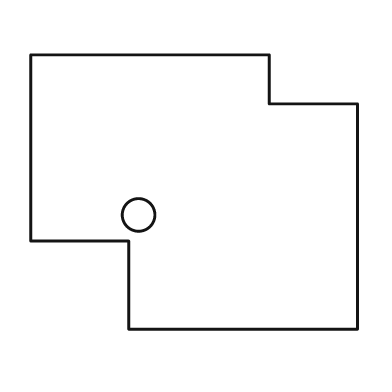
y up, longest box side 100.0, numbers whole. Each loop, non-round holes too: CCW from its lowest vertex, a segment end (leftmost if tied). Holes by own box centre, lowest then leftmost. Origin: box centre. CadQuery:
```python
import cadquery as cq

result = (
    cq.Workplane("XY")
    .moveTo(-20.0, -42.0)
    .lineTo(50.0, -42.0)
    .lineTo(50.0, 27.0)
    .lineTo(23.0, 27.0)
    .lineTo(23.0, 42.0)
    .lineTo(-50.0, 42.0)
    .lineTo(-50.0, -15.0)
    .lineTo(-20.0, -15.0)
    .close()
    .moveTo(-17.0, -7.0)
    .circle(5.0)
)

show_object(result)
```